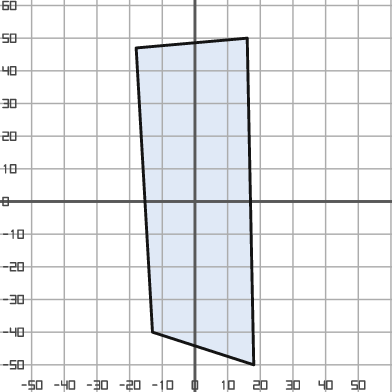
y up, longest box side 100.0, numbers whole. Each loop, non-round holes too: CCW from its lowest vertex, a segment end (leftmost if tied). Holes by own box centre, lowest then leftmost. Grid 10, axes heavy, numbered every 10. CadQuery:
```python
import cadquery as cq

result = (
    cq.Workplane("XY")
    .moveTo(18.0, -50.0)
    .lineTo(16.0, 50.0)
    .lineTo(-18.0, 47.0)
    .lineTo(-13.0, -40.0)
    .close()
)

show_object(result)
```